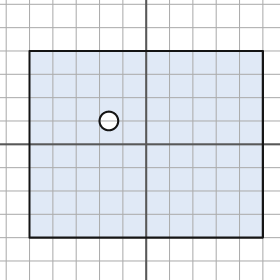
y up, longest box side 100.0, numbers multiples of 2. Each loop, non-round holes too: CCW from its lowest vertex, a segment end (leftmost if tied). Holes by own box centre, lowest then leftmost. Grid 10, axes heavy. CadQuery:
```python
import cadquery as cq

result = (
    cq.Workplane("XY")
    .moveTo(-50.0, -40.0)
    .lineTo(50.0, -40.0)
    .lineTo(50.0, 40.0)
    .lineTo(-50.0, 40.0)
    .close()
    .moveTo(-16.0, 10.0)
    .circle(4.0)
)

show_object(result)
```